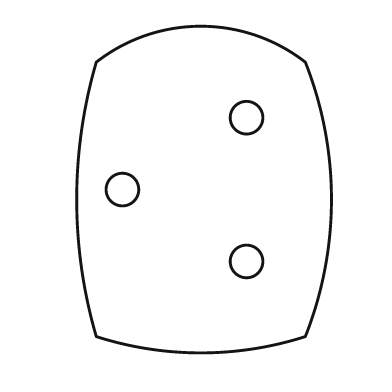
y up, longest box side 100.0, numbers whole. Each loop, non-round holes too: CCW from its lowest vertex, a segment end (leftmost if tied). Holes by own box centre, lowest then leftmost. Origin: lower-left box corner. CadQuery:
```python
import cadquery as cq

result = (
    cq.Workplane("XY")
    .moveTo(6.0, 5.0)
    .threePointArc((38.0, 0.0), (70.0, 5.0))
    .threePointArc((78.0, 47.0), (70.0, 89.0))
    .threePointArc((38.0, 100.0), (6.0, 89.0))
    .threePointArc((0.0, 47.0), (6.0, 5.0))
    .close()
    .moveTo(52.0, 28.0)
    .circle(5.0)
    .moveTo(14.0, 50.0)
    .circle(5.0)
    .moveTo(52.0, 72.0)
    .circle(5.0)
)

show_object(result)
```